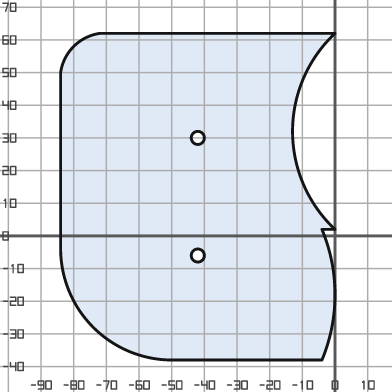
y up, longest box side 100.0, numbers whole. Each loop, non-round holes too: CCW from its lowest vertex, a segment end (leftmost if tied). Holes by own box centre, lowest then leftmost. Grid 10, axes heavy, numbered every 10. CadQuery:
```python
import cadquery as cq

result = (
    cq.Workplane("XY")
    .moveTo(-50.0, -38.0)
    .lineTo(-4.0, -38.0)
    .threePointArc((0.0, -18.0), (-4.0, 2.0))
    .lineTo(0.0, 2.0)
    .threePointArc((-13.0, 32.0), (0.0, 62.0))
    .lineTo(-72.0, 62.0)
    .threePointArc((-80.0, 58.0), (-84.0, 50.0))
    .lineTo(-84.0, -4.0)
    .threePointArc((-74.0, -28.0), (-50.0, -38.0))
    .close()
    .moveTo(-42.0, -6.0)
    .circle(2.0)
    .moveTo(-42.0, 30.0)
    .circle(2.0)
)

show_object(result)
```